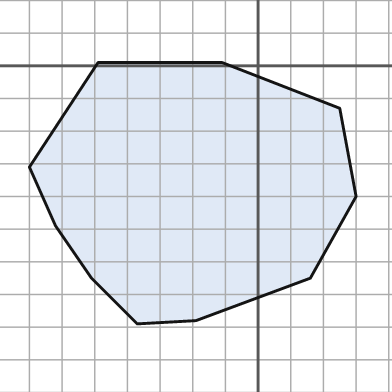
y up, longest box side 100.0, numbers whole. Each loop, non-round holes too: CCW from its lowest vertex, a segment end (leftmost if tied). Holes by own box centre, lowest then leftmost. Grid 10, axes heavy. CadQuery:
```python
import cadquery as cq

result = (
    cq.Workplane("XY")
    .moveTo(-37.0, -79.0)
    .lineTo(-19.0, -78.0)
    .lineTo(16.0, -65.0)
    .lineTo(30.0, -40.0)
    .lineTo(25.0, -13.0)
    .lineTo(-11.0, 1.0)
    .lineTo(-49.0, 1.0)
    .lineTo(-70.0, -31.0)
    .lineTo(-62.0, -49.0)
    .lineTo(-51.0, -65.0)
    .close()
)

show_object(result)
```